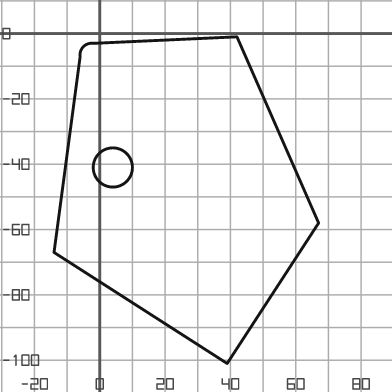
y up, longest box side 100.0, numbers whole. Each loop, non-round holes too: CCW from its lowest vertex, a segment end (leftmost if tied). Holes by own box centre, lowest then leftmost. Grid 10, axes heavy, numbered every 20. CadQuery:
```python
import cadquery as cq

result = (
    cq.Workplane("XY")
    .moveTo(39.0, -101.0)
    .lineTo(67.0, -58.0)
    .lineTo(42.0, -1.0)
    .lineTo(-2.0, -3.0)
    .threePointArc((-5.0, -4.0), (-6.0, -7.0))
    .lineTo(-14.0, -67.0)
    .close()
    .moveTo(4.0, -41.0)
    .circle(6.0)
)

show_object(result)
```